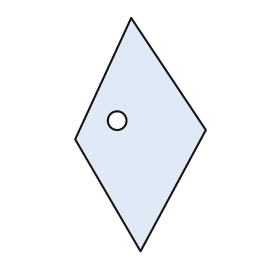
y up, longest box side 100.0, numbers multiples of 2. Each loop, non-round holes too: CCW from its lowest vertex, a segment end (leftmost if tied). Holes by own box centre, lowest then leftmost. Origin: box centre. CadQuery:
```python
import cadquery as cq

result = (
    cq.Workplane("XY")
    .moveTo(0.0, -50.0)
    .lineTo(28.0, 2.0)
    .lineTo(-4.0, 50.0)
    .lineTo(-28.0, -2.0)
    .close()
    .moveTo(-10.0, 6.0)
    .circle(4.0)
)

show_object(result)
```